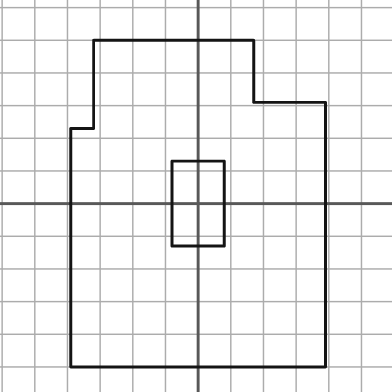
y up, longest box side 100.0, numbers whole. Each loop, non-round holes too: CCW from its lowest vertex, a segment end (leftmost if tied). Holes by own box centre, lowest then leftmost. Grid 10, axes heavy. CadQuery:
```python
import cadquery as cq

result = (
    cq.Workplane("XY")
    .moveTo(-39.0, -50.0)
    .lineTo(39.0, -50.0)
    .lineTo(39.0, 31.0)
    .lineTo(17.0, 31.0)
    .lineTo(17.0, 50.0)
    .lineTo(-32.0, 50.0)
    .lineTo(-32.0, 23.0)
    .lineTo(-39.0, 23.0)
    .close()
    .moveTo(-8.0, -13.0)
    .lineTo(8.0, -13.0)
    .lineTo(8.0, 13.0)
    .lineTo(-8.0, 13.0)
    .close()
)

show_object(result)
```